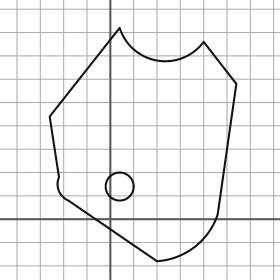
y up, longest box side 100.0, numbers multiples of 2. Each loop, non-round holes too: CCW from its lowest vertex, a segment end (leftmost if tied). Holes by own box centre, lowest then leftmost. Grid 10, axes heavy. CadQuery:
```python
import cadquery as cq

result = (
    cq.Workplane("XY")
    .moveTo(20.0, -18.0)
    .threePointArc((36.0, -12.0), (46.0, 2.0))
    .lineTo(54.0, 58.0)
    .lineTo(40.0, 76.0)
    .threePointArc((20.0, 68.0), (4.0, 82.0))
    .lineTo(-26.0, 44.0)
    .lineTo(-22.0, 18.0)
    .threePointArc((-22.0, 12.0), (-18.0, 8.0))
    .close()
    .moveTo(4.0, 14.0)
    .circle(6.0)
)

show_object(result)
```